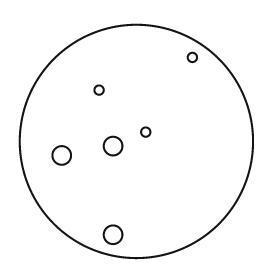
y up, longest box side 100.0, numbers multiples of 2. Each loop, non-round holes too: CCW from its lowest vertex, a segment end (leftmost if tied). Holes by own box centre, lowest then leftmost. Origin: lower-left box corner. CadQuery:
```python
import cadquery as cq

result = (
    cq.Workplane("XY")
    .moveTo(50.0, 50.0)
    .circle(50.0)
    .moveTo(40.0, 10.0)
    .circle(4.0)
    .moveTo(18.0, 44.0)
    .circle(4.0)
    .moveTo(40.0, 48.0)
    .circle(4.0)
    .moveTo(54.0, 54.0)
    .circle(2.0)
    .moveTo(34.0, 72.0)
    .circle(2.0)
    .moveTo(74.0, 86.0)
    .circle(2.0)
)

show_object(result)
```